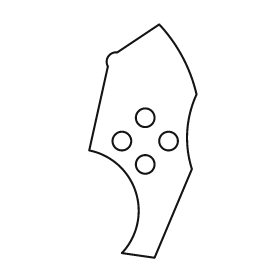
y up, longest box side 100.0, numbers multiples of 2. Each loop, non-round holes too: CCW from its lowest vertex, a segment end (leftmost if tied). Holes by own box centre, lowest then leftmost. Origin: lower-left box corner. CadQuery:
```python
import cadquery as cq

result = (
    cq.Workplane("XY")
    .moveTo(28.0, 0.0)
    .lineTo(44.0, 38.0)
    .threePointArc((42.0, 54.0), (46.0, 70.0))
    .threePointArc((40.0, 86.0), (30.0, 100.0))
    .lineTo(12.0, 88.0)
    .threePointArc((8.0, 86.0), (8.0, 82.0))
    .lineTo(0.0, 46.0)
    .threePointArc((20.0, 28.0), (14.0, 2.0))
    .close()
    .moveTo(24.0, 40.0)
    .circle(4.0)
    .moveTo(14.0, 50.0)
    .circle(4.0)
    .moveTo(34.0, 50.0)
    .circle(4.0)
    .moveTo(24.0, 60.0)
    .circle(4.0)
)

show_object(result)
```